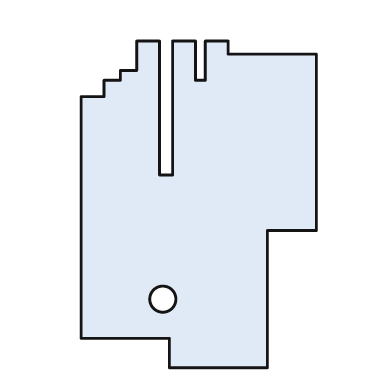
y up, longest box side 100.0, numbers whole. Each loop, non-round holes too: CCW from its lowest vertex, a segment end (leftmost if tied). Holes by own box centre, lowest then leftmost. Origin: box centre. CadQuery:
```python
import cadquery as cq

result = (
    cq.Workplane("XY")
    .moveTo(-9.0, -50.0)
    .lineTo(21.0, -50.0)
    .lineTo(21.0, -8.0)
    .lineTo(36.0, -8.0)
    .lineTo(36.0, 46.0)
    .lineTo(9.0, 46.0)
    .lineTo(9.0, 50.0)
    .lineTo(2.0, 50.0)
    .lineTo(2.0, 38.0)
    .lineTo(-1.0, 38.0)
    .lineTo(-1.0, 50.0)
    .lineTo(-8.0, 50.0)
    .lineTo(-8.0, 9.0)
    .lineTo(-12.0, 9.0)
    .lineTo(-12.0, 50.0)
    .lineTo(-19.0, 50.0)
    .lineTo(-19.0, 41.0)
    .lineTo(-24.0, 41.0)
    .lineTo(-24.0, 38.0)
    .lineTo(-29.0, 38.0)
    .lineTo(-29.0, 33.0)
    .lineTo(-36.0, 33.0)
    .lineTo(-36.0, -41.0)
    .lineTo(-9.0, -41.0)
    .close()
    .moveTo(-11.0, -29.0)
    .circle(4.0)
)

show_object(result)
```